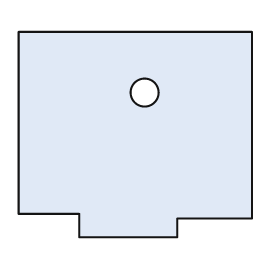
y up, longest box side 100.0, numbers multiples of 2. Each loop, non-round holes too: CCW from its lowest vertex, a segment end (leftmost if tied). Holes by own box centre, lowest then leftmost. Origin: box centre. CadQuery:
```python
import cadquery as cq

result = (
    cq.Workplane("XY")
    .moveTo(-24.0, -44.0)
    .lineTo(18.0, -44.0)
    .lineTo(18.0, -36.0)
    .lineTo(50.0, -36.0)
    .lineTo(50.0, 44.0)
    .lineTo(-50.0, 44.0)
    .lineTo(-50.0, -34.0)
    .lineTo(-24.0, -34.0)
    .close()
    .moveTo(4.0, 18.0)
    .circle(6.0)
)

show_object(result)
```